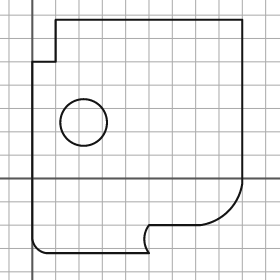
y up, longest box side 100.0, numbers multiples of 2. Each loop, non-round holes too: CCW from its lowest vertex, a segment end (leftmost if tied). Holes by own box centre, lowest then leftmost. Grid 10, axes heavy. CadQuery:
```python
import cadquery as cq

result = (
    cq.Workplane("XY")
    .moveTo(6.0, -32.0)
    .lineTo(50.0, -32.0)
    .threePointArc((48.0, -26.0), (50.0, -20.0))
    .lineTo(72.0, -20.0)
    .threePointArc((84.0, -14.0), (90.0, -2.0))
    .lineTo(90.0, 68.0)
    .lineTo(10.0, 68.0)
    .lineTo(10.0, 50.0)
    .lineTo(0.0, 50.0)
    .lineTo(0.0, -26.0)
    .threePointArc((2.0, -30.0), (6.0, -32.0))
    .close()
    .moveTo(22.0, 24.0)
    .circle(10.0)
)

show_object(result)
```